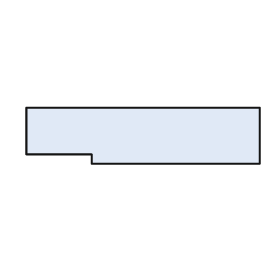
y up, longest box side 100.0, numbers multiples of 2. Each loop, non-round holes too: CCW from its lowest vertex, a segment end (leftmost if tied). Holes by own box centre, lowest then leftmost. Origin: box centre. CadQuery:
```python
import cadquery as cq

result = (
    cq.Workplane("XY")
    .moveTo(-22.0, -12.0)
    .lineTo(50.0, -12.0)
    .lineTo(50.0, 12.0)
    .lineTo(-50.0, 12.0)
    .lineTo(-50.0, -8.0)
    .lineTo(-22.0, -8.0)
    .close()
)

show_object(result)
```